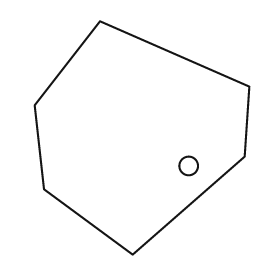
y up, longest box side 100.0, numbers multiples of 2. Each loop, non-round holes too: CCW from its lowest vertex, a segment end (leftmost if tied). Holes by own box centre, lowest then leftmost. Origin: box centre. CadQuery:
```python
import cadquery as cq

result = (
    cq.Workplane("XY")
    .moveTo(-4.0, -50.0)
    .lineTo(44.0, -8.0)
    .lineTo(46.0, 22.0)
    .lineTo(-18.0, 50.0)
    .lineTo(-46.0, 14.0)
    .lineTo(-42.0, -22.0)
    .close()
    .moveTo(20.0, -12.0)
    .circle(4.0)
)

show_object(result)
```